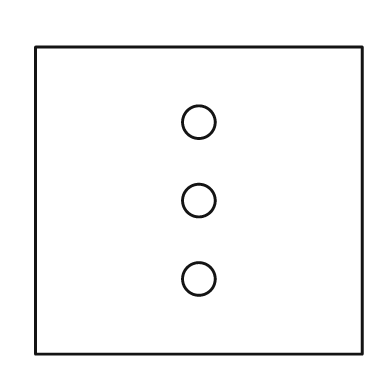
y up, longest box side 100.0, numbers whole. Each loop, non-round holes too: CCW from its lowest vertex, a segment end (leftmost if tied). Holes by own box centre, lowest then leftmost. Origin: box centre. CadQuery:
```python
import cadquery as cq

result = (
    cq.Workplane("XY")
    .moveTo(-50.0, -47.0)
    .lineTo(50.0, -47.0)
    .lineTo(50.0, 47.0)
    .lineTo(-50.0, 47.0)
    .close()
    .moveTo(0.0, -24.0)
    .circle(5.0)
    .moveTo(0.0, 0.0)
    .circle(5.0)
    .moveTo(0.0, 24.0)
    .circle(5.0)
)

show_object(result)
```